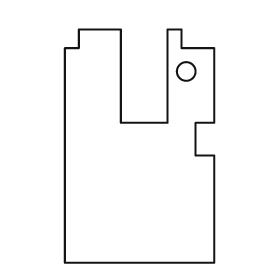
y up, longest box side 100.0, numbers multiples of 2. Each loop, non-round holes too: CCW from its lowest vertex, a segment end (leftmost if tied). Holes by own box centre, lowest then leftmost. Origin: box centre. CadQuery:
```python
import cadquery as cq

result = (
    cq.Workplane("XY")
    .moveTo(-32.0, -50.0)
    .lineTo(32.0, -50.0)
    .lineTo(32.0, -4.0)
    .lineTo(24.0, -4.0)
    .lineTo(24.0, 10.0)
    .lineTo(32.0, 10.0)
    .lineTo(32.0, 42.0)
    .lineTo(18.0, 42.0)
    .lineTo(18.0, 50.0)
    .lineTo(12.0, 50.0)
    .lineTo(12.0, 10.0)
    .lineTo(-8.0, 10.0)
    .lineTo(-8.0, 50.0)
    .lineTo(-26.0, 50.0)
    .lineTo(-26.0, 42.0)
    .lineTo(-32.0, 42.0)
    .close()
    .moveTo(20.0, 32.0)
    .circle(4.0)
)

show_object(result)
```